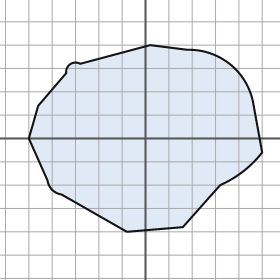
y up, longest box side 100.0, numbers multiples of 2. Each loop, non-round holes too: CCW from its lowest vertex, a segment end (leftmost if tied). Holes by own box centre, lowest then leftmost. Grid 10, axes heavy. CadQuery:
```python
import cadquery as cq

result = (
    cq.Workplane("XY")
    .moveTo(-8.0, -40.0)
    .lineTo(16.0, -38.0)
    .lineTo(32.0, -20.0)
    .threePointArc((42.0, -14.0), (50.0, -6.0))
    .lineTo(46.0, 16.0)
    .threePointArc((36.0, 32.0), (18.0, 38.0))
    .lineTo(2.0, 40.0)
    .lineTo(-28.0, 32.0)
    .threePointArc((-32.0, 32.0), (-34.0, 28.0))
    .lineTo(-46.0, 14.0)
    .lineTo(-50.0, 0.0)
    .lineTo(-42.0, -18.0)
    .threePointArc((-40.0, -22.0), (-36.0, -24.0))
    .close()
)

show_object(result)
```